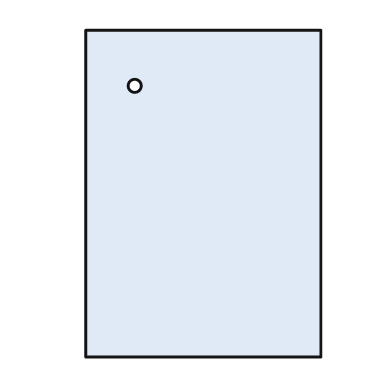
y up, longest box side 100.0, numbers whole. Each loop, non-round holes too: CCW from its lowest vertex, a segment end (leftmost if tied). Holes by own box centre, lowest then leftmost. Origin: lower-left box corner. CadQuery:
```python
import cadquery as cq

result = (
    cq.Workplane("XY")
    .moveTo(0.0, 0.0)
    .lineTo(72.0, 0.0)
    .lineTo(72.0, 100.0)
    .lineTo(0.0, 100.0)
    .close()
    .moveTo(15.0, 83.0)
    .circle(2.0)
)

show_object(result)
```